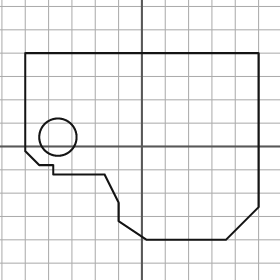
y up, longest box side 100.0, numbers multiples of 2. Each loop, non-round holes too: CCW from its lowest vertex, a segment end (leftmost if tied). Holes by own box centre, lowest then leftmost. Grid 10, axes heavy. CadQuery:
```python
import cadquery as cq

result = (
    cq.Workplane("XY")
    .moveTo(2.0, -40.0)
    .lineTo(36.0, -40.0)
    .lineTo(50.0, -26.0)
    .lineTo(50.0, 40.0)
    .lineTo(-50.0, 40.0)
    .lineTo(-50.0, -2.0)
    .lineTo(-44.0, -8.0)
    .lineTo(-38.0, -8.0)
    .lineTo(-38.0, -12.0)
    .lineTo(-16.0, -12.0)
    .lineTo(-10.0, -24.0)
    .lineTo(-10.0, -32.0)
    .close()
    .moveTo(-36.0, 4.0)
    .circle(8.0)
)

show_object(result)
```